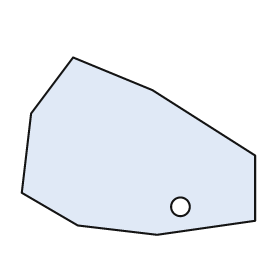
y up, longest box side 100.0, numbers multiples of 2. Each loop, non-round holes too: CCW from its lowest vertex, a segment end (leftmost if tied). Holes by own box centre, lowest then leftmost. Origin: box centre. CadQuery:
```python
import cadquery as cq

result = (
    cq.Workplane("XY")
    .moveTo(8.0, -38.0)
    .lineTo(50.0, -32.0)
    .lineTo(50.0, -4.0)
    .lineTo(6.0, 24.0)
    .lineTo(-28.0, 38.0)
    .lineTo(-46.0, 14.0)
    .lineTo(-50.0, -20.0)
    .lineTo(-26.0, -34.0)
    .close()
    .moveTo(18.0, -26.0)
    .circle(4.0)
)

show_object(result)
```